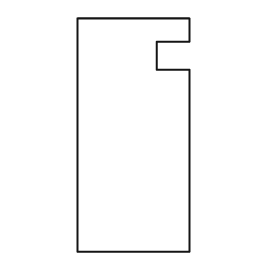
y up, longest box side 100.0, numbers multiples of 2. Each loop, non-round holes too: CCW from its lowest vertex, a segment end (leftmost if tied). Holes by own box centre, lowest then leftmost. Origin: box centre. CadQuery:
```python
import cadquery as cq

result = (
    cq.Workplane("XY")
    .moveTo(-24.0, -50.0)
    .lineTo(24.0, -50.0)
    .lineTo(24.0, 28.0)
    .lineTo(10.0, 28.0)
    .lineTo(10.0, 40.0)
    .lineTo(24.0, 40.0)
    .lineTo(24.0, 50.0)
    .lineTo(-24.0, 50.0)
    .close()
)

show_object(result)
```